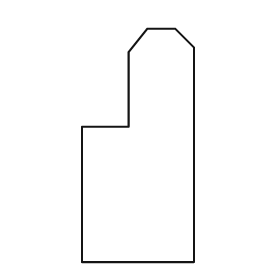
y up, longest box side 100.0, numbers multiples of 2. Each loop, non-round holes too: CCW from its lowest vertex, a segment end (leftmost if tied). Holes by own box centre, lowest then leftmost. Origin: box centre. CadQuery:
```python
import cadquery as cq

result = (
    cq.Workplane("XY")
    .moveTo(-24.0, -50.0)
    .lineTo(24.0, -50.0)
    .lineTo(24.0, 42.0)
    .lineTo(16.0, 50.0)
    .lineTo(4.0, 50.0)
    .lineTo(-4.0, 40.0)
    .lineTo(-4.0, 8.0)
    .lineTo(-24.0, 8.0)
    .close()
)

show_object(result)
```